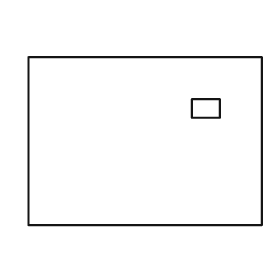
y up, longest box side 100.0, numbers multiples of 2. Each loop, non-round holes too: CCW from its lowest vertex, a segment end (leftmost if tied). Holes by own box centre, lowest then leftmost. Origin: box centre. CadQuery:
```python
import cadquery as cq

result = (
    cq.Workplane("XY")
    .moveTo(-50.0, -36.0)
    .lineTo(50.0, -36.0)
    .lineTo(50.0, 36.0)
    .lineTo(-50.0, 36.0)
    .close()
    .moveTo(20.0, 10.0)
    .lineTo(32.0, 10.0)
    .lineTo(32.0, 18.0)
    .lineTo(20.0, 18.0)
    .close()
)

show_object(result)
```